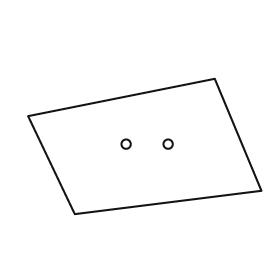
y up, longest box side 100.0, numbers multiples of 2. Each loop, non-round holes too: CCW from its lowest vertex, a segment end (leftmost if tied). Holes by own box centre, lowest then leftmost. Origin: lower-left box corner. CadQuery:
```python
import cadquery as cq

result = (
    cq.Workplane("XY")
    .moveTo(20.0, 0.0)
    .lineTo(100.0, 10.0)
    .lineTo(80.0, 58.0)
    .lineTo(0.0, 42.0)
    .close()
    .moveTo(42.0, 30.0)
    .circle(2.0)
    .moveTo(60.0, 30.0)
    .circle(2.0)
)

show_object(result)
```